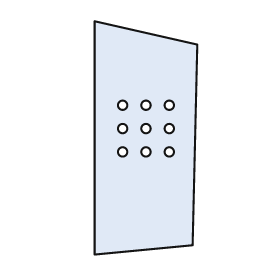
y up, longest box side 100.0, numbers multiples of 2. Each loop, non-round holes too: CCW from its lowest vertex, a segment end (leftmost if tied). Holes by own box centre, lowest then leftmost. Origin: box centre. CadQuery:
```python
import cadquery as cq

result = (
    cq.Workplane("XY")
    .moveTo(-22.0, -50.0)
    .lineTo(20.0, -46.0)
    .lineTo(22.0, 40.0)
    .lineTo(-22.0, 50.0)
    .close()
    .moveTo(-10.0, -6.0)
    .circle(2.0)
    .moveTo(0.0, -6.0)
    .circle(2.0)
    .moveTo(10.0, -6.0)
    .circle(2.0)
    .moveTo(-10.0, 4.0)
    .circle(2.0)
    .moveTo(0.0, 4.0)
    .circle(2.0)
    .moveTo(10.0, 4.0)
    .circle(2.0)
    .moveTo(-10.0, 14.0)
    .circle(2.0)
    .moveTo(0.0, 14.0)
    .circle(2.0)
    .moveTo(10.0, 14.0)
    .circle(2.0)
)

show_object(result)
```